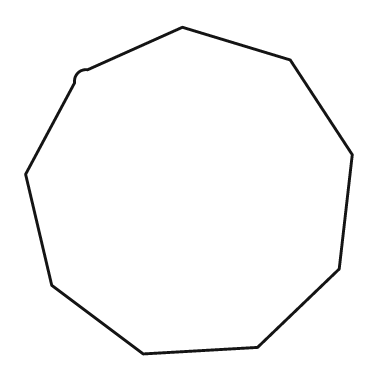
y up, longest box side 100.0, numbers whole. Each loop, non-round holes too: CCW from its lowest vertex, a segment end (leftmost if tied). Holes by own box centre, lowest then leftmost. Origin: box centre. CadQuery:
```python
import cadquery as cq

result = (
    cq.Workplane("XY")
    .moveTo(-14.0, -50.0)
    .lineTo(21.0, -48.0)
    .lineTo(46.0, -24.0)
    .lineTo(50.0, 11.0)
    .lineTo(31.0, 40.0)
    .lineTo(-2.0, 50.0)
    .lineTo(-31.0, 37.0)
    .threePointArc((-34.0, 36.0), (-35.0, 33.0))
    .lineTo(-50.0, 5.0)
    .lineTo(-42.0, -29.0)
    .close()
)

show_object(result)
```